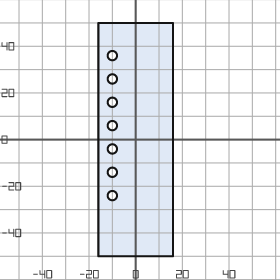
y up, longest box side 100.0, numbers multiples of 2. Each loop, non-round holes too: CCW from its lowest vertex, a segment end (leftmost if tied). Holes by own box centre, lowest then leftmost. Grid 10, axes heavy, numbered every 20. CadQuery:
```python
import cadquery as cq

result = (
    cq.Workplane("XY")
    .moveTo(-16.0, -50.0)
    .lineTo(16.0, -50.0)
    .lineTo(16.0, 50.0)
    .lineTo(-16.0, 50.0)
    .close()
    .moveTo(-10.0, -24.0)
    .circle(2.0)
    .moveTo(-10.0, -14.0)
    .circle(2.0)
    .moveTo(-10.0, -4.0)
    .circle(2.0)
    .moveTo(-10.0, 6.0)
    .circle(2.0)
    .moveTo(-10.0, 16.0)
    .circle(2.0)
    .moveTo(-10.0, 26.0)
    .circle(2.0)
    .moveTo(-10.0, 36.0)
    .circle(2.0)
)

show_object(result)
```